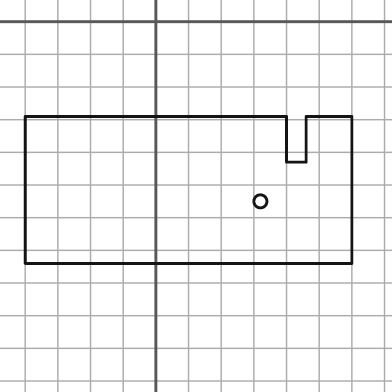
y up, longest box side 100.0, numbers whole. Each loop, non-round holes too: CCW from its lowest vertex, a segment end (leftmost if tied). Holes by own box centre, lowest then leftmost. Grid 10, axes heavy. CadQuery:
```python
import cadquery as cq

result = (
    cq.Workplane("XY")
    .moveTo(-40.0, -74.0)
    .lineTo(60.0, -74.0)
    .lineTo(60.0, -29.0)
    .lineTo(46.0, -29.0)
    .lineTo(46.0, -43.0)
    .lineTo(40.0, -43.0)
    .lineTo(40.0, -29.0)
    .lineTo(-40.0, -29.0)
    .close()
    .moveTo(32.0, -55.0)
    .circle(2.0)
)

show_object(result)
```